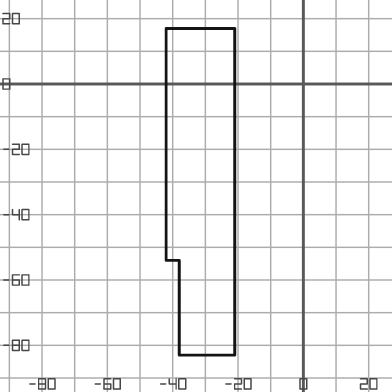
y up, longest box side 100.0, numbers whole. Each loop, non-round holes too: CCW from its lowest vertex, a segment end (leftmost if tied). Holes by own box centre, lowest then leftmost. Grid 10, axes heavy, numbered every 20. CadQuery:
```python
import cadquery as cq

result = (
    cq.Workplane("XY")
    .moveTo(-38.0, -83.0)
    .lineTo(-21.0, -83.0)
    .lineTo(-21.0, 17.0)
    .lineTo(-42.0, 17.0)
    .lineTo(-42.0, -54.0)
    .lineTo(-38.0, -54.0)
    .close()
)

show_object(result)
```